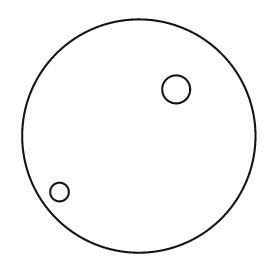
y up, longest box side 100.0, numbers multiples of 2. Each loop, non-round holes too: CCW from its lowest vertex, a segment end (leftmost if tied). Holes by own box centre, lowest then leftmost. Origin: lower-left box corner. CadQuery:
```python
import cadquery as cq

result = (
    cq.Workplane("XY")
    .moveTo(50.0, 50.0)
    .circle(50.0)
    .moveTo(16.0, 26.0)
    .circle(4.0)
    .moveTo(66.0, 70.0)
    .circle(6.0)
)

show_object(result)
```